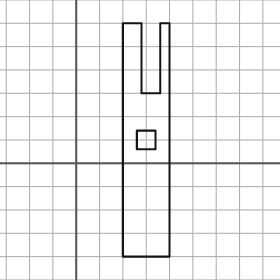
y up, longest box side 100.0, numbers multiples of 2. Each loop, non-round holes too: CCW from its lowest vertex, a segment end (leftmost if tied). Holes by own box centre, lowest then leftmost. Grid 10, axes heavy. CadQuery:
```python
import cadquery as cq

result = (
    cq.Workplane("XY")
    .moveTo(20.0, -40.0)
    .lineTo(40.0, -40.0)
    .lineTo(40.0, 60.0)
    .lineTo(36.0, 60.0)
    .lineTo(36.0, 30.0)
    .lineTo(28.0, 30.0)
    .lineTo(28.0, 60.0)
    .lineTo(20.0, 60.0)
    .close()
    .moveTo(26.0, 6.0)
    .lineTo(34.0, 6.0)
    .lineTo(34.0, 14.0)
    .lineTo(26.0, 14.0)
    .close()
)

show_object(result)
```